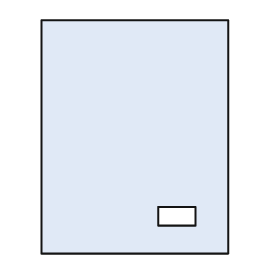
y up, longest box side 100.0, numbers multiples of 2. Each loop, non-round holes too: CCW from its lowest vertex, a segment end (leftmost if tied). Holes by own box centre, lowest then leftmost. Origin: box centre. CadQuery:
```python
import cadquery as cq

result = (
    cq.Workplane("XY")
    .moveTo(-40.0, -50.0)
    .lineTo(40.0, -50.0)
    .lineTo(40.0, 50.0)
    .lineTo(-40.0, 50.0)
    .close()
    .moveTo(10.0, -38.0)
    .lineTo(26.0, -38.0)
    .lineTo(26.0, -30.0)
    .lineTo(10.0, -30.0)
    .close()
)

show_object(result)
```